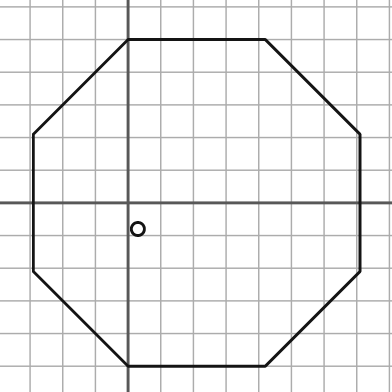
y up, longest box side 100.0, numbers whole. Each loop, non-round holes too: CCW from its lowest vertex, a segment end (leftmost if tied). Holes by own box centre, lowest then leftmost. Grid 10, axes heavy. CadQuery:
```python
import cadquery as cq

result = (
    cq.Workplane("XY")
    .moveTo(0.0, -50.0)
    .lineTo(42.0, -50.0)
    .lineTo(71.0, -21.0)
    .lineTo(71.0, 21.0)
    .lineTo(42.0, 50.0)
    .lineTo(0.0, 50.0)
    .lineTo(-29.0, 21.0)
    .lineTo(-29.0, -21.0)
    .close()
    .moveTo(3.0, -8.0)
    .circle(2.0)
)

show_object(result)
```